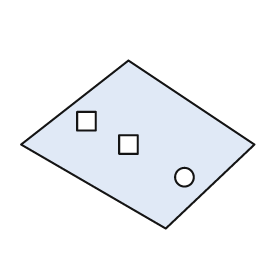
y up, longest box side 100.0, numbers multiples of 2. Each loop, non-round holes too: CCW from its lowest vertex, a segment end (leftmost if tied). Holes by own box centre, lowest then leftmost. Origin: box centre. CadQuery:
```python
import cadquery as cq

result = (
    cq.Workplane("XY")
    .moveTo(12.0, -36.0)
    .lineTo(50.0, 0.0)
    .lineTo(-4.0, 36.0)
    .lineTo(-50.0, 0.0)
    .close()
    .moveTo(20.0, -14.0)
    .circle(4.0)
    .moveTo(-8.0, -4.0)
    .lineTo(0.0, -4.0)
    .lineTo(0.0, 4.0)
    .lineTo(-8.0, 4.0)
    .close()
    .moveTo(-26.0, 6.0)
    .lineTo(-18.0, 6.0)
    .lineTo(-18.0, 14.0)
    .lineTo(-26.0, 14.0)
    .close()
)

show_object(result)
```